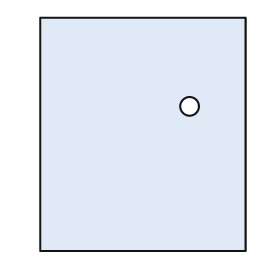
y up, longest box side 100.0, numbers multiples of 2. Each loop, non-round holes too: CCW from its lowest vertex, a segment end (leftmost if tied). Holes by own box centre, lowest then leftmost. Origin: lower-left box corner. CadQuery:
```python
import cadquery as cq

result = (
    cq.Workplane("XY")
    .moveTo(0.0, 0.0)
    .lineTo(88.0, 0.0)
    .lineTo(88.0, 100.0)
    .lineTo(0.0, 100.0)
    .close()
    .moveTo(64.0, 62.0)
    .circle(4.0)
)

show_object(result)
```